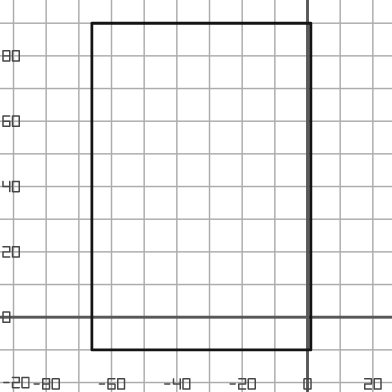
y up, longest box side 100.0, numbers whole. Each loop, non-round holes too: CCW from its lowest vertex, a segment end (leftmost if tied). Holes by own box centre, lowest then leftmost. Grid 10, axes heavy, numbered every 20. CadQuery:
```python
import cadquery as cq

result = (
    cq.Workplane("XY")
    .moveTo(-66.0, -10.0)
    .lineTo(1.0, -10.0)
    .lineTo(1.0, 90.0)
    .lineTo(-66.0, 90.0)
    .close()
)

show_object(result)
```